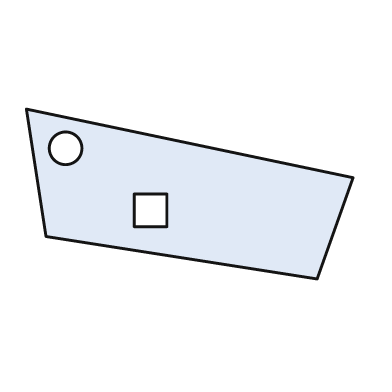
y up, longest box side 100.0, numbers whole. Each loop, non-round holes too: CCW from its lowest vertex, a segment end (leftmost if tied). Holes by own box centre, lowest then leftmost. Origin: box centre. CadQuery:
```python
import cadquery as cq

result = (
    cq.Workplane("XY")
    .moveTo(39.0, -26.0)
    .lineTo(50.0, 5.0)
    .lineTo(-50.0, 26.0)
    .lineTo(-44.0, -13.0)
    .close()
    .moveTo(-17.0, -10.0)
    .lineTo(-7.0, -10.0)
    .lineTo(-7.0, 0.0)
    .lineTo(-17.0, 0.0)
    .close()
    .moveTo(-38.0, 14.0)
    .circle(5.0)
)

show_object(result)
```